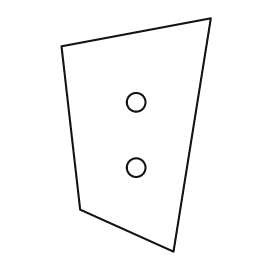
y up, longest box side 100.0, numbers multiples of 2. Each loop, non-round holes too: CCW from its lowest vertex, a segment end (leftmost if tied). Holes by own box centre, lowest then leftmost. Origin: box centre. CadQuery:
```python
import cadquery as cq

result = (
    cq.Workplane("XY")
    .moveTo(16.0, -50.0)
    .lineTo(32.0, 50.0)
    .lineTo(-32.0, 38.0)
    .lineTo(-24.0, -32.0)
    .close()
    .moveTo(0.0, -14.0)
    .circle(4.0)
    .moveTo(0.0, 14.0)
    .circle(4.0)
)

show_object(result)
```